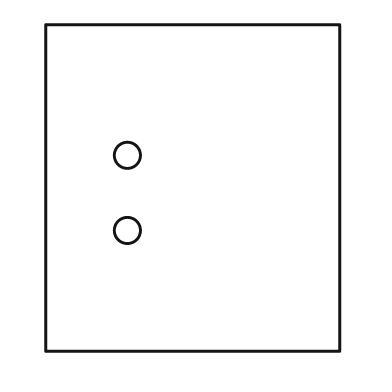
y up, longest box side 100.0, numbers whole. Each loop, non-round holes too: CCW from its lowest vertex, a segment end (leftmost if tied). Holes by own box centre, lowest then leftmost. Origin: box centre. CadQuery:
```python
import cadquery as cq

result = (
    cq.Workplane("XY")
    .moveTo(-45.0, -50.0)
    .lineTo(45.0, -50.0)
    .lineTo(45.0, 50.0)
    .lineTo(-45.0, 50.0)
    .close()
    .moveTo(-20.0, -13.0)
    .circle(4.0)
    .moveTo(-20.0, 10.0)
    .circle(4.0)
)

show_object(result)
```